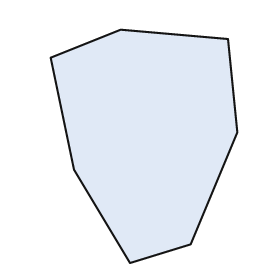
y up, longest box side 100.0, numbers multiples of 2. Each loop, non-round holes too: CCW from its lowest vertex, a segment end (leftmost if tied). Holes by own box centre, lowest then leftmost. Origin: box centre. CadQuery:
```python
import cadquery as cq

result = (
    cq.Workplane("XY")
    .moveTo(-6.0, -50.0)
    .lineTo(20.0, -42.0)
    .lineTo(40.0, 6.0)
    .lineTo(36.0, 46.0)
    .lineTo(-10.0, 50.0)
    .lineTo(-40.0, 38.0)
    .lineTo(-30.0, -10.0)
    .close()
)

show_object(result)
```